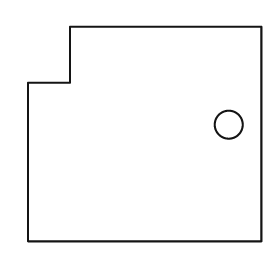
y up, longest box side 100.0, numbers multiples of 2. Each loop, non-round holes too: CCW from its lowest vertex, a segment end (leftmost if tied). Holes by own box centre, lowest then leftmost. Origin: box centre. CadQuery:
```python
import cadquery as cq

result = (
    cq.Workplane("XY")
    .moveTo(-50.0, -46.0)
    .lineTo(50.0, -46.0)
    .lineTo(50.0, 46.0)
    .lineTo(-32.0, 46.0)
    .lineTo(-32.0, 22.0)
    .lineTo(-50.0, 22.0)
    .close()
    .moveTo(36.0, 4.0)
    .circle(6.0)
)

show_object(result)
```